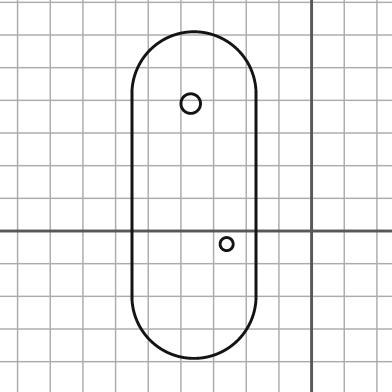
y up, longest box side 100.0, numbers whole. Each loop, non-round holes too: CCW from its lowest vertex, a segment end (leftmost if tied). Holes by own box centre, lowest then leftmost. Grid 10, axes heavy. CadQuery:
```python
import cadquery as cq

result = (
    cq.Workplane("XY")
    .moveTo(-55.0, -20.0)
    .threePointArc((-36.0, -39.0), (-17.0, -20.0))
    .lineTo(-17.0, 42.0)
    .threePointArc((-36.0, 61.0), (-55.0, 42.0))
    .close()
    .moveTo(-26.0, -4.0)
    .circle(2.0)
    .moveTo(-37.0, 39.0)
    .circle(3.0)
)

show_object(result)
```